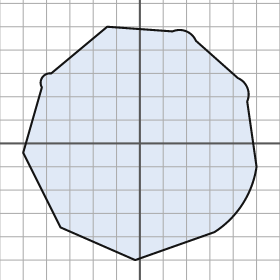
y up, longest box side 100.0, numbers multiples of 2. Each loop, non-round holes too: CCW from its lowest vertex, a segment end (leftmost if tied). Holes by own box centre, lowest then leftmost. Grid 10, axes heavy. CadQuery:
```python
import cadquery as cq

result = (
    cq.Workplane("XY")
    .moveTo(-2.0, -50.0)
    .lineTo(32.0, -38.0)
    .threePointArc((44.0, -26.0), (50.0, -10.0))
    .lineTo(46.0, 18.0)
    .threePointArc((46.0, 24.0), (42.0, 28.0))
    .lineTo(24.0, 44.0)
    .threePointArc((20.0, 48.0), (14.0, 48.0))
    .lineTo(-14.0, 50.0)
    .lineTo(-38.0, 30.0)
    .threePointArc((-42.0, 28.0), (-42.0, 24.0))
    .lineTo(-50.0, -4.0)
    .lineTo(-34.0, -36.0)
    .close()
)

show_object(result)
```